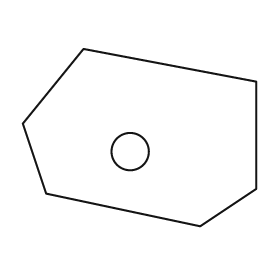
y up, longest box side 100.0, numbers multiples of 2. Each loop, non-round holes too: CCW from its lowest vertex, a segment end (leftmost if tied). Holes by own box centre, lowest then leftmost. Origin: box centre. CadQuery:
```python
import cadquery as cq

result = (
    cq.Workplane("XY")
    .moveTo(26.0, -38.0)
    .lineTo(50.0, -22.0)
    .lineTo(50.0, 24.0)
    .lineTo(-24.0, 38.0)
    .lineTo(-50.0, 6.0)
    .lineTo(-40.0, -24.0)
    .close()
    .moveTo(-4.0, -6.0)
    .circle(8.0)
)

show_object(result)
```